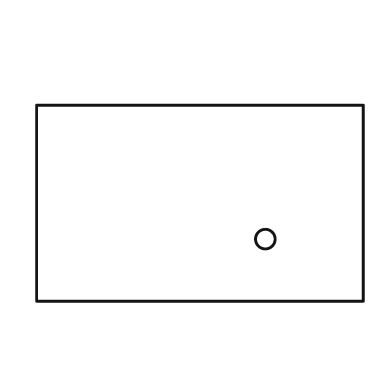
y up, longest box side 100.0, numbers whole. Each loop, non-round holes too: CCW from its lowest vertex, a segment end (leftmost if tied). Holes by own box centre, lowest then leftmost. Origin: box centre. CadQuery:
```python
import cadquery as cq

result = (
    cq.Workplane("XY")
    .moveTo(-50.0, -30.0)
    .lineTo(50.0, -30.0)
    .lineTo(50.0, 30.0)
    .lineTo(-50.0, 30.0)
    .close()
    .moveTo(20.0, -11.0)
    .circle(3.0)
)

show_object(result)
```